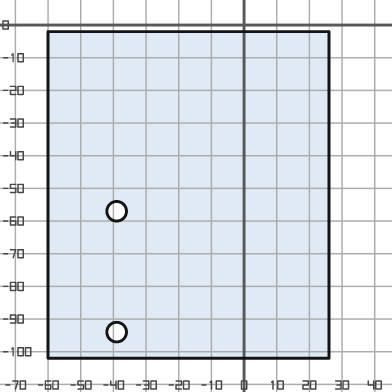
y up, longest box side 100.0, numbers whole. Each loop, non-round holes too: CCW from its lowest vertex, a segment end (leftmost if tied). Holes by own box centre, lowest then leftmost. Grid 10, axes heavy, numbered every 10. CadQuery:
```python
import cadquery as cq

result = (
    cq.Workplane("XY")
    .moveTo(-60.0, -102.0)
    .lineTo(26.0, -102.0)
    .lineTo(26.0, -2.0)
    .lineTo(-60.0, -2.0)
    .close()
    .moveTo(-39.0, -94.0)
    .circle(3.0)
    .moveTo(-39.0, -57.0)
    .circle(3.0)
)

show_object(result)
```